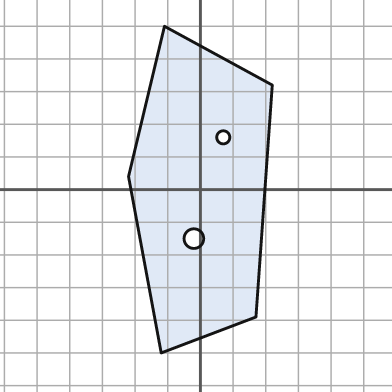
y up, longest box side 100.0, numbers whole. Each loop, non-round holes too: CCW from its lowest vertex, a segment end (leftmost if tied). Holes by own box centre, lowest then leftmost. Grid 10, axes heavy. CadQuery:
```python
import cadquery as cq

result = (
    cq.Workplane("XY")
    .moveTo(-12.0, -50.0)
    .lineTo(17.0, -39.0)
    .lineTo(22.0, 32.0)
    .lineTo(-11.0, 50.0)
    .lineTo(-22.0, 4.0)
    .close()
    .moveTo(-2.0, -15.0)
    .circle(3.0)
    .moveTo(7.0, 16.0)
    .circle(2.0)
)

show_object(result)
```